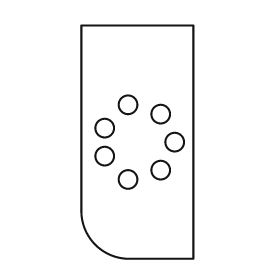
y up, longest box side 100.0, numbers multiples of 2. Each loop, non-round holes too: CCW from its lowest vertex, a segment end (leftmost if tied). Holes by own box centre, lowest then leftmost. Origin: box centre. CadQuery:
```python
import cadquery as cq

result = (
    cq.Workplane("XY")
    .moveTo(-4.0, -50.0)
    .lineTo(24.0, -50.0)
    .lineTo(24.0, 50.0)
    .lineTo(-24.0, 50.0)
    .lineTo(-24.0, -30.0)
    .threePointArc((-18.0, -44.0), (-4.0, -50.0))
    .close()
    .moveTo(-4.0, -16.0)
    .circle(4.0)
    .moveTo(10.0, -12.0)
    .circle(4.0)
    .moveTo(-14.0, -6.0)
    .circle(4.0)
    .moveTo(16.0, 0.0)
    .circle(4.0)
    .moveTo(-14.0, 6.0)
    .circle(4.0)
    .moveTo(10.0, 12.0)
    .circle(4.0)
    .moveTo(-4.0, 16.0)
    .circle(4.0)
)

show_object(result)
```